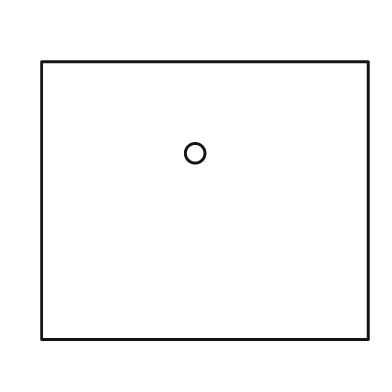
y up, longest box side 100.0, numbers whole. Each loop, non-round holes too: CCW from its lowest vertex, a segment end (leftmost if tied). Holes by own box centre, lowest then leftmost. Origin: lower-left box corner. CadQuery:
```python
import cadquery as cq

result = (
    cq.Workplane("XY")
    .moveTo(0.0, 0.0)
    .lineTo(100.0, 0.0)
    .lineTo(100.0, 85.0)
    .lineTo(0.0, 85.0)
    .close()
    .moveTo(47.0, 57.0)
    .circle(3.0)
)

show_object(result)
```